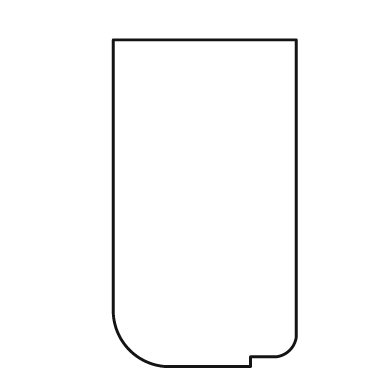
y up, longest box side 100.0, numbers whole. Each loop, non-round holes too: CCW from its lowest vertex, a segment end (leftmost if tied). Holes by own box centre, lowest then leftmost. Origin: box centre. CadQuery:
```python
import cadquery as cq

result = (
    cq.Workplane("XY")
    .moveTo(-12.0, -50.0)
    .lineTo(14.0, -50.0)
    .lineTo(14.0, -47.0)
    .lineTo(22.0, -47.0)
    .threePointArc((26.0, -45.0), (28.0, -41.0))
    .lineTo(28.0, 50.0)
    .lineTo(-28.0, 50.0)
    .lineTo(-28.0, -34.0)
    .threePointArc((-23.0, -45.0), (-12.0, -50.0))
    .close()
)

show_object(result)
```